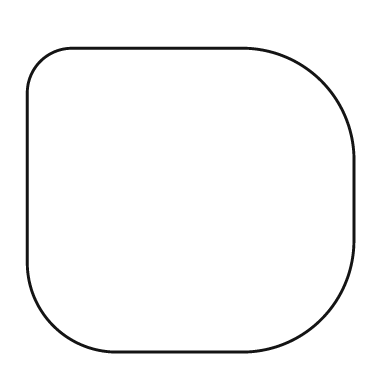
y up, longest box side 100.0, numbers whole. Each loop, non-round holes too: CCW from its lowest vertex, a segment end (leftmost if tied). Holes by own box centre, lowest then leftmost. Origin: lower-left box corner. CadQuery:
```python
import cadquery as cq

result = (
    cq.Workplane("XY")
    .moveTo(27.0, 0.0)
    .lineTo(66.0, 0.0)
    .threePointArc((90.0, 10.0), (100.0, 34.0))
    .lineTo(100.0, 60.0)
    .threePointArc((90.0, 83.0), (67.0, 93.0))
    .lineTo(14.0, 93.0)
    .threePointArc((4.0, 89.0), (0.0, 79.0))
    .lineTo(0.0, 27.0)
    .threePointArc((8.0, 8.0), (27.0, 0.0))
    .close()
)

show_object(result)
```